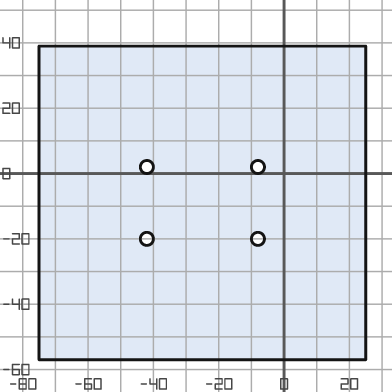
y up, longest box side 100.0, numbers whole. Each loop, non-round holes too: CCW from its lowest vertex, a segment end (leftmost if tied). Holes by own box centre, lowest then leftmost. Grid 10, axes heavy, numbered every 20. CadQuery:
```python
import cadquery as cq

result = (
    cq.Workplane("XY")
    .moveTo(-75.0, -57.0)
    .lineTo(25.0, -57.0)
    .lineTo(25.0, 39.0)
    .lineTo(-75.0, 39.0)
    .close()
    .moveTo(-42.0, -20.0)
    .circle(2.0)
    .moveTo(-8.0, -20.0)
    .circle(2.0)
    .moveTo(-42.0, 2.0)
    .circle(2.0)
    .moveTo(-8.0, 2.0)
    .circle(2.0)
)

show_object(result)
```